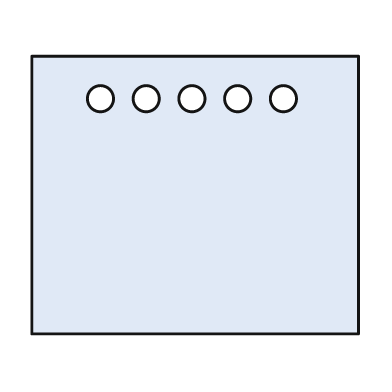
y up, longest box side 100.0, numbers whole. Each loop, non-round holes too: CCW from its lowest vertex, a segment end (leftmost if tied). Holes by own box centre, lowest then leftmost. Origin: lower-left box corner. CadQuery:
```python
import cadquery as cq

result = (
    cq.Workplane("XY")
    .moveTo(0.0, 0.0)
    .lineTo(100.0, 0.0)
    .lineTo(100.0, 85.0)
    .lineTo(0.0, 85.0)
    .close()
    .moveTo(21.0, 72.0)
    .circle(4.0)
    .moveTo(35.0, 72.0)
    .circle(4.0)
    .moveTo(49.0, 72.0)
    .circle(4.0)
    .moveTo(63.0, 72.0)
    .circle(4.0)
    .moveTo(77.0, 72.0)
    .circle(4.0)
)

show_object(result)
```